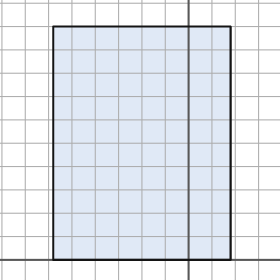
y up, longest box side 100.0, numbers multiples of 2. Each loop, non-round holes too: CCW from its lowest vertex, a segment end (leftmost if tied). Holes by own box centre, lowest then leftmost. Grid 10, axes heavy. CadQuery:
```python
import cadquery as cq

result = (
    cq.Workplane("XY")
    .moveTo(-58.0, 0.0)
    .lineTo(18.0, 0.0)
    .lineTo(18.0, 100.0)
    .lineTo(-58.0, 100.0)
    .close()
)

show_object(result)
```